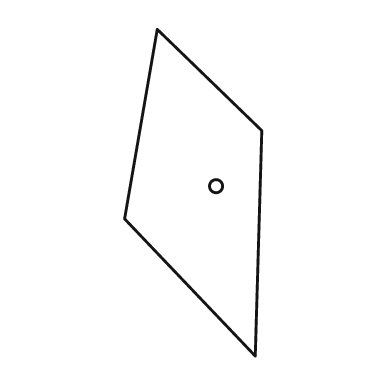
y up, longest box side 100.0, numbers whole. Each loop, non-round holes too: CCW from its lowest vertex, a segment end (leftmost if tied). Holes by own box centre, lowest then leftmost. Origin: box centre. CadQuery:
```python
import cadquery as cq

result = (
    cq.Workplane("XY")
    .moveTo(19.0, -50.0)
    .lineTo(21.0, 19.0)
    .lineTo(-11.0, 50.0)
    .lineTo(-21.0, -8.0)
    .close()
    .moveTo(7.0, 2.0)
    .circle(2.0)
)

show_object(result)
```